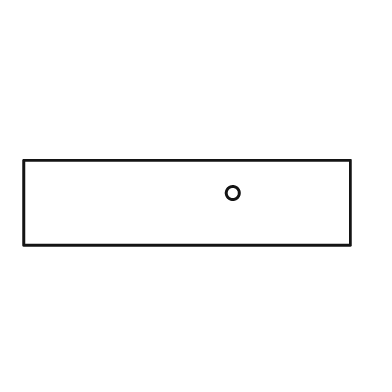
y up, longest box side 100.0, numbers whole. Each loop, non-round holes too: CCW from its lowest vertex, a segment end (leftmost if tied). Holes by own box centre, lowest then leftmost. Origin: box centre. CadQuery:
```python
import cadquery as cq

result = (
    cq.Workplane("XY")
    .moveTo(-50.0, -13.0)
    .lineTo(50.0, -13.0)
    .lineTo(50.0, 13.0)
    .lineTo(-50.0, 13.0)
    .close()
    .moveTo(14.0, 3.0)
    .circle(2.0)
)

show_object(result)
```